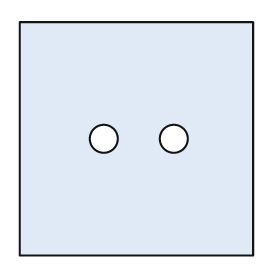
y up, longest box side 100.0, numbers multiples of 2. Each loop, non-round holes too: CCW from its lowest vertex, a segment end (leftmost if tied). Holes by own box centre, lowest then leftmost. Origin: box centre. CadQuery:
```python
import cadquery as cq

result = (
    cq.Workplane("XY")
    .moveTo(-50.0, -50.0)
    .lineTo(50.0, -50.0)
    .lineTo(50.0, 50.0)
    .lineTo(-50.0, 50.0)
    .close()
    .moveTo(-14.0, 0.0)
    .circle(6.0)
    .moveTo(16.0, 0.0)
    .circle(6.0)
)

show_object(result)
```